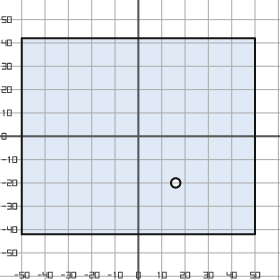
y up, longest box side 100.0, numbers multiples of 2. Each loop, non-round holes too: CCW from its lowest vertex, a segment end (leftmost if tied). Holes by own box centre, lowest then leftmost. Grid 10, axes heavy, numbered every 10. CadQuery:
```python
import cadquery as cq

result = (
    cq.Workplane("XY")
    .moveTo(-50.0, -42.0)
    .lineTo(50.0, -42.0)
    .lineTo(50.0, 42.0)
    .lineTo(-50.0, 42.0)
    .close()
    .moveTo(16.0, -20.0)
    .circle(2.0)
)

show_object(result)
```